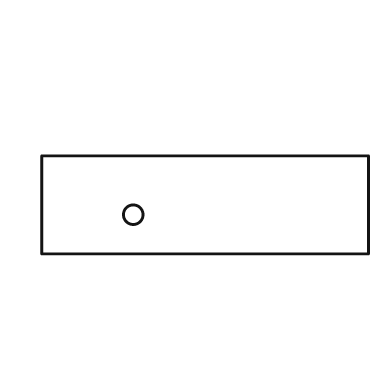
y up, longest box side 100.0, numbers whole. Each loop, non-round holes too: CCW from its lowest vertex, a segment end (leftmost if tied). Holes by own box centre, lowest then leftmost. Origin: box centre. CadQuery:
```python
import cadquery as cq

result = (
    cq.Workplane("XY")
    .moveTo(-50.0, -15.0)
    .lineTo(50.0, -15.0)
    .lineTo(50.0, 15.0)
    .lineTo(-50.0, 15.0)
    .close()
    .moveTo(-22.0, -3.0)
    .circle(3.0)
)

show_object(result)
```